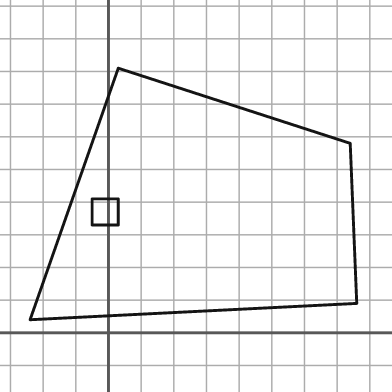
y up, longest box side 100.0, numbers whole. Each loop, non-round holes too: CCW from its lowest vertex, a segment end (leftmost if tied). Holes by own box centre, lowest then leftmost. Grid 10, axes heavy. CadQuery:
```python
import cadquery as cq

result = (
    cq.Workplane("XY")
    .moveTo(-24.0, 4.0)
    .lineTo(76.0, 9.0)
    .lineTo(74.0, 58.0)
    .lineTo(3.0, 81.0)
    .close()
    .moveTo(-5.0, 33.0)
    .lineTo(3.0, 33.0)
    .lineTo(3.0, 41.0)
    .lineTo(-5.0, 41.0)
    .close()
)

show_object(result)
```